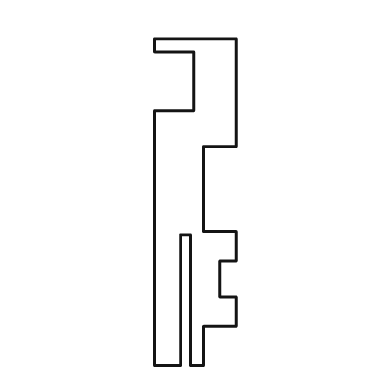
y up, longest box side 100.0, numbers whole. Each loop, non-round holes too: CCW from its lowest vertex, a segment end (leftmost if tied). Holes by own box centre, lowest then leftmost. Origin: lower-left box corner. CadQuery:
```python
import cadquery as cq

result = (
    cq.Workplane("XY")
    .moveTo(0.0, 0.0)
    .lineTo(8.0, 0.0)
    .lineTo(8.0, 40.0)
    .lineTo(11.0, 40.0)
    .lineTo(11.0, 0.0)
    .lineTo(15.0, 0.0)
    .lineTo(15.0, 12.0)
    .lineTo(25.0, 12.0)
    .lineTo(25.0, 21.0)
    .lineTo(20.0, 21.0)
    .lineTo(20.0, 32.0)
    .lineTo(25.0, 32.0)
    .lineTo(25.0, 41.0)
    .lineTo(15.0, 41.0)
    .lineTo(15.0, 67.0)
    .lineTo(25.0, 67.0)
    .lineTo(25.0, 100.0)
    .lineTo(0.0, 100.0)
    .lineTo(0.0, 96.0)
    .lineTo(12.0, 96.0)
    .lineTo(12.0, 78.0)
    .lineTo(0.0, 78.0)
    .close()
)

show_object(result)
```